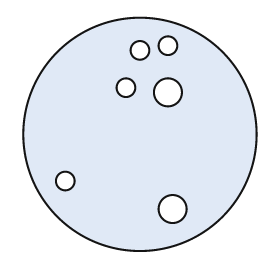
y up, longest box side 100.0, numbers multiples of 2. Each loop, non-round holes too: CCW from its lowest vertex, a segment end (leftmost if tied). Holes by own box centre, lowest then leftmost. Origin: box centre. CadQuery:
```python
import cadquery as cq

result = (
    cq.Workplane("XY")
    .moveTo(0.0, 0.0)
    .circle(50.0)
    .moveTo(14.0, -32.0)
    .circle(6.0)
    .moveTo(-32.0, -20.0)
    .circle(4.0)
    .moveTo(12.0, 18.0)
    .circle(6.0)
    .moveTo(-6.0, 20.0)
    .circle(4.0)
    .moveTo(0.0, 36.0)
    .circle(4.0)
    .moveTo(12.0, 38.0)
    .circle(4.0)
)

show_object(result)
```